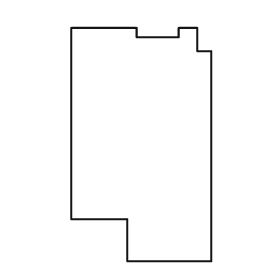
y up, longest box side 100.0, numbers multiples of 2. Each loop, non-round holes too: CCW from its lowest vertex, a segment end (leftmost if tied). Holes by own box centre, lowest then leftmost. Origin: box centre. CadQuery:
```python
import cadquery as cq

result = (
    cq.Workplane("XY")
    .moveTo(-6.0, -50.0)
    .lineTo(30.0, -50.0)
    .lineTo(30.0, 40.0)
    .lineTo(24.0, 40.0)
    .lineTo(24.0, 50.0)
    .lineTo(16.0, 50.0)
    .lineTo(16.0, 46.0)
    .lineTo(-2.0, 46.0)
    .lineTo(-2.0, 50.0)
    .lineTo(-30.0, 50.0)
    .lineTo(-30.0, -32.0)
    .lineTo(-6.0, -32.0)
    .close()
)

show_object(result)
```